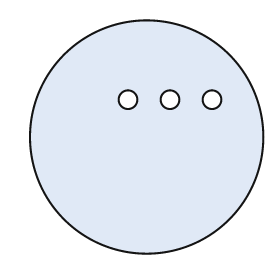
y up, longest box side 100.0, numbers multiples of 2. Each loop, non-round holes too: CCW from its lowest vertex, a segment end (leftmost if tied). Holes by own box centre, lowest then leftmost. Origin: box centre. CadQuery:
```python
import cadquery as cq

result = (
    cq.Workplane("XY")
    .moveTo(0.0, 0.0)
    .circle(50.0)
    .moveTo(-8.0, 16.0)
    .circle(4.0)
    .moveTo(10.0, 16.0)
    .circle(4.0)
    .moveTo(28.0, 16.0)
    .circle(4.0)
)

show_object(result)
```